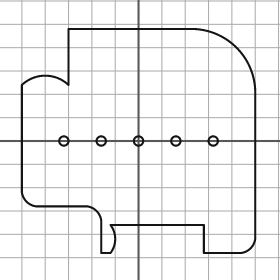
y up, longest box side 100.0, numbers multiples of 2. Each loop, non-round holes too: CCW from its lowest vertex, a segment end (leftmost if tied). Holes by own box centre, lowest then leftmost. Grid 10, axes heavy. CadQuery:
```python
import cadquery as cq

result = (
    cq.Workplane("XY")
    .moveTo(-16.0, -48.0)
    .lineTo(-12.0, -48.0)
    .threePointArc((-10.0, -42.0), (-12.0, -36.0))
    .lineTo(28.0, -36.0)
    .lineTo(28.0, -48.0)
    .lineTo(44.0, -48.0)
    .threePointArc((48.0, -46.0), (50.0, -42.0))
    .lineTo(50.0, 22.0)
    .threePointArc((42.0, 40.0), (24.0, 48.0))
    .lineTo(-30.0, 48.0)
    .lineTo(-30.0, 24.0)
    .threePointArc((-40.0, 28.0), (-50.0, 24.0))
    .lineTo(-50.0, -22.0)
    .threePointArc((-48.0, -26.0), (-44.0, -28.0))
    .lineTo(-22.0, -28.0)
    .threePointArc((-18.0, -30.0), (-16.0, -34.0))
    .close()
    .moveTo(-32.0, 0.0)
    .circle(2.0)
    .moveTo(-16.0, 0.0)
    .circle(2.0)
    .moveTo(0.0, 0.0)
    .circle(2.0)
    .moveTo(16.0, 0.0)
    .circle(2.0)
    .moveTo(32.0, 0.0)
    .circle(2.0)
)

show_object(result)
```